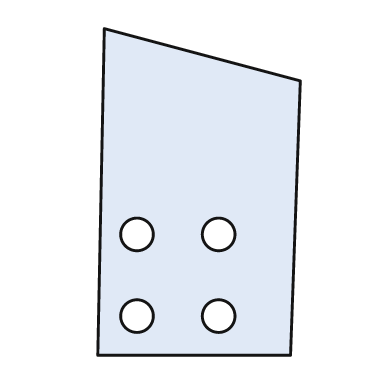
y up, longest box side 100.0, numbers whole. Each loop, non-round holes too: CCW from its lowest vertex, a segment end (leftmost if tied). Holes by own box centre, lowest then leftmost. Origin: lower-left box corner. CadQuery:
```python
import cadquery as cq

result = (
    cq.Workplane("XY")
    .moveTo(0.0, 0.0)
    .lineTo(59.0, 0.0)
    .lineTo(62.0, 84.0)
    .lineTo(2.0, 100.0)
    .close()
    .moveTo(12.0, 12.0)
    .circle(5.0)
    .moveTo(37.0, 12.0)
    .circle(5.0)
    .moveTo(12.0, 37.0)
    .circle(5.0)
    .moveTo(37.0, 37.0)
    .circle(5.0)
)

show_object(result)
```